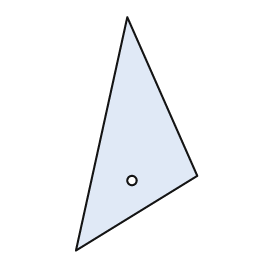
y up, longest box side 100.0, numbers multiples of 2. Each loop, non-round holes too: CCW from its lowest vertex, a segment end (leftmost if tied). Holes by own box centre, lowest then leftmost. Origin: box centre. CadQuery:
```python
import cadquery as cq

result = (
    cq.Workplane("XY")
    .moveTo(-26.0, -50.0)
    .lineTo(26.0, -18.0)
    .lineTo(-4.0, 50.0)
    .close()
    .moveTo(-2.0, -20.0)
    .circle(2.0)
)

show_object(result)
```